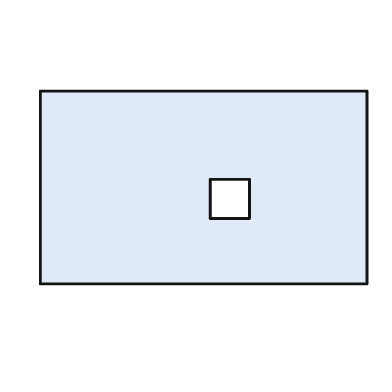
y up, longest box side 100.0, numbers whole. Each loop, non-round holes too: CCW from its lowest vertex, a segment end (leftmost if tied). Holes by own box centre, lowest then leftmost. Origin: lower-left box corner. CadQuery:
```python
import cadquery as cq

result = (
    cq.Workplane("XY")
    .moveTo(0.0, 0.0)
    .lineTo(100.0, 0.0)
    .lineTo(100.0, 59.0)
    .lineTo(0.0, 59.0)
    .close()
    .moveTo(52.0, 20.0)
    .lineTo(64.0, 20.0)
    .lineTo(64.0, 32.0)
    .lineTo(52.0, 32.0)
    .close()
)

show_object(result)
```